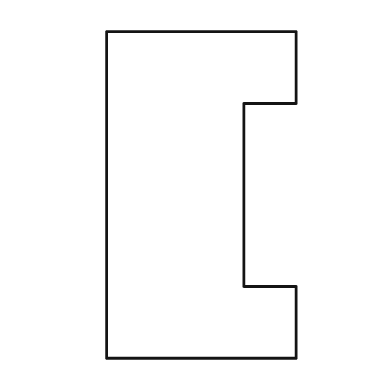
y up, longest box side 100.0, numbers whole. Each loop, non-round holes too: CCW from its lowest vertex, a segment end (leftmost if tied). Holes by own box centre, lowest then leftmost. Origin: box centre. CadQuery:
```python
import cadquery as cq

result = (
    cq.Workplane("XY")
    .moveTo(-29.0, -50.0)
    .lineTo(29.0, -50.0)
    .lineTo(29.0, -28.0)
    .lineTo(13.0, -28.0)
    .lineTo(13.0, 28.0)
    .lineTo(29.0, 28.0)
    .lineTo(29.0, 50.0)
    .lineTo(-29.0, 50.0)
    .close()
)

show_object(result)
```